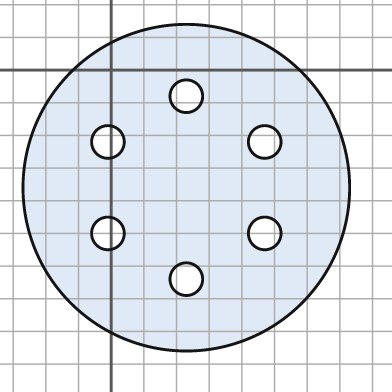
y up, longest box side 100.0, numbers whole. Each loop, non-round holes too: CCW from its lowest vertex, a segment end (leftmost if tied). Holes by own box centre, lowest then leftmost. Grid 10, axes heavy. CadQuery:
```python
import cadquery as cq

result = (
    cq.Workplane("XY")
    .moveTo(23.0, -36.0)
    .circle(50.0)
    .moveTo(23.0, -64.0)
    .circle(5.0)
    .moveTo(-1.0, -50.0)
    .circle(5.0)
    .moveTo(47.0, -50.0)
    .circle(5.0)
    .moveTo(-1.0, -22.0)
    .circle(5.0)
    .moveTo(47.0, -22.0)
    .circle(5.0)
    .moveTo(23.0, -8.0)
    .circle(5.0)
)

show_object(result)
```